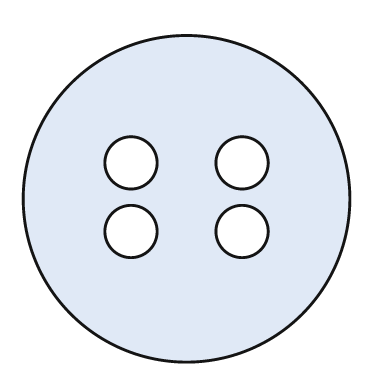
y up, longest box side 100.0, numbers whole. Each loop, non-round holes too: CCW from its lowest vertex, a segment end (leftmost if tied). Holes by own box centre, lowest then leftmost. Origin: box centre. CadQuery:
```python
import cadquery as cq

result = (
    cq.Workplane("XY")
    .moveTo(0.0, 0.0)
    .circle(50.0)
    .moveTo(-17.0, -10.0)
    .circle(8.0)
    .moveTo(17.0, -10.0)
    .circle(8.0)
    .moveTo(-17.0, 11.0)
    .circle(8.0)
    .moveTo(17.0, 11.0)
    .circle(8.0)
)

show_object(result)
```